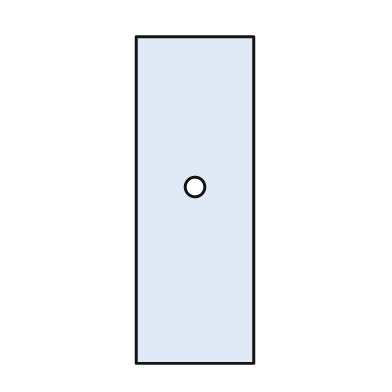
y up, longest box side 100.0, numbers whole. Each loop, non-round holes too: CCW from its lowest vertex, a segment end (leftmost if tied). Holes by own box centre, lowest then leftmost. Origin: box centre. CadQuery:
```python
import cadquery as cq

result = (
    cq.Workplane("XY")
    .moveTo(-18.0, -50.0)
    .lineTo(18.0, -50.0)
    .lineTo(18.0, 50.0)
    .lineTo(-18.0, 50.0)
    .close()
    .moveTo(0.0, 4.0)
    .circle(3.0)
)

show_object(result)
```